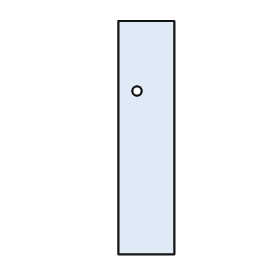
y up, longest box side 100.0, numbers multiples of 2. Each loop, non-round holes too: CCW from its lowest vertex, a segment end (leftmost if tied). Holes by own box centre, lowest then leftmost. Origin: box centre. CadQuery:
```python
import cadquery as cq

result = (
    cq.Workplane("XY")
    .moveTo(-12.0, -50.0)
    .lineTo(12.0, -50.0)
    .lineTo(12.0, 50.0)
    .lineTo(-12.0, 50.0)
    .close()
    .moveTo(-4.0, 20.0)
    .circle(2.0)
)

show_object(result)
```